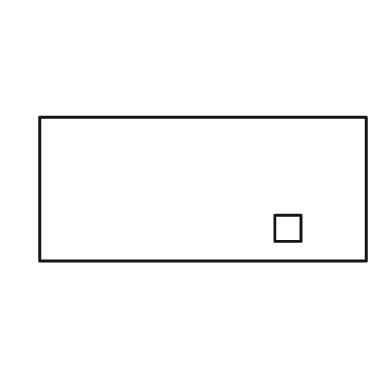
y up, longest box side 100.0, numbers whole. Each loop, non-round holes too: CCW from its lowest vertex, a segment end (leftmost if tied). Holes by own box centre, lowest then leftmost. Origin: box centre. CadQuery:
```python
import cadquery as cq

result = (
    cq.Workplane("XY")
    .moveTo(-50.0, -22.0)
    .lineTo(50.0, -22.0)
    .lineTo(50.0, 22.0)
    .lineTo(-50.0, 22.0)
    .close()
    .moveTo(22.0, -16.0)
    .lineTo(30.0, -16.0)
    .lineTo(30.0, -8.0)
    .lineTo(22.0, -8.0)
    .close()
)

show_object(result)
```